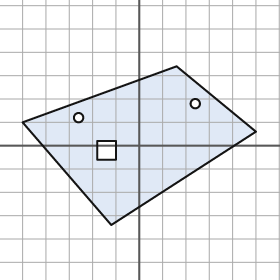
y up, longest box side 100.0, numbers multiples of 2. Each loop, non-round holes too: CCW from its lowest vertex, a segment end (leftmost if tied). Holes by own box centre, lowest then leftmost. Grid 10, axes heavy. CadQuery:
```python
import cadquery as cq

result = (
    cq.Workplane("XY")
    .moveTo(-12.0, -34.0)
    .lineTo(50.0, 6.0)
    .lineTo(16.0, 34.0)
    .lineTo(-50.0, 10.0)
    .close()
    .moveTo(-18.0, -6.0)
    .lineTo(-10.0, -6.0)
    .lineTo(-10.0, 2.0)
    .lineTo(-18.0, 2.0)
    .close()
    .moveTo(-26.0, 12.0)
    .circle(2.0)
    .moveTo(24.0, 18.0)
    .circle(2.0)
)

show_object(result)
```